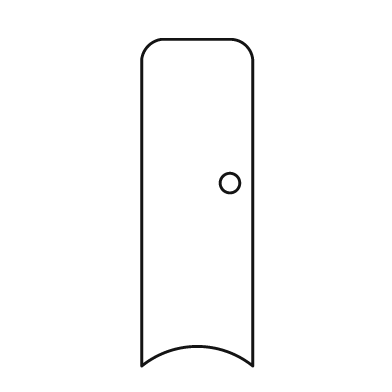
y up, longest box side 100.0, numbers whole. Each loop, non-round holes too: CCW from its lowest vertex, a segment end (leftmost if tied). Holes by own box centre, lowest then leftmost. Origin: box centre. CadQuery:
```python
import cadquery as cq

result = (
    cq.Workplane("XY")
    .moveTo(-17.0, -50.0)
    .threePointArc((0.0, -44.0), (17.0, -50.0))
    .lineTo(17.0, 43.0)
    .threePointArc((15.0, 48.0), (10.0, 50.0))
    .lineTo(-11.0, 50.0)
    .threePointArc((-15.0, 48.0), (-17.0, 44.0))
    .close()
    .moveTo(10.0, 6.0)
    .circle(3.0)
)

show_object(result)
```